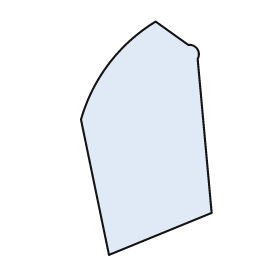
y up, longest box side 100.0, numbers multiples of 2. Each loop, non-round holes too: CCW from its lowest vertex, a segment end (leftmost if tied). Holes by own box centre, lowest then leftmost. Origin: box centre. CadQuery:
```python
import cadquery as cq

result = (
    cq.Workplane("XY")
    .moveTo(-16.0, -50.0)
    .lineTo(28.0, -32.0)
    .lineTo(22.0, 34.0)
    .threePointArc((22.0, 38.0), (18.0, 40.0))
    .lineTo(4.0, 50.0)
    .threePointArc((-16.0, 32.0), (-28.0, 8.0))
    .close()
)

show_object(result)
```